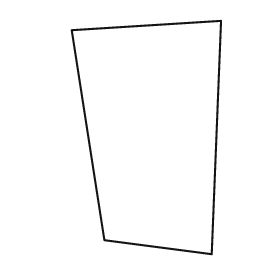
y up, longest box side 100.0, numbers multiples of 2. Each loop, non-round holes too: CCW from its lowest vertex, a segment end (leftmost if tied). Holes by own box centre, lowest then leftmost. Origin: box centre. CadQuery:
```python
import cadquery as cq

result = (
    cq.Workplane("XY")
    .moveTo(28.0, -50.0)
    .lineTo(32.0, 50.0)
    .lineTo(-32.0, 46.0)
    .lineTo(-18.0, -44.0)
    .close()
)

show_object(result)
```